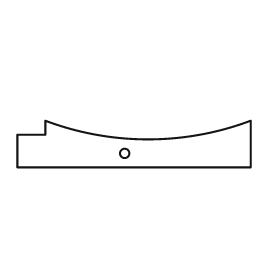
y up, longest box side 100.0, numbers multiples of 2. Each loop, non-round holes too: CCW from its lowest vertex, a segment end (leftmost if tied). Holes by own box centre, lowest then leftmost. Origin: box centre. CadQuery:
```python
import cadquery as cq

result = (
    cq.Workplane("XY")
    .moveTo(-50.0, -10.0)
    .lineTo(50.0, -10.0)
    .lineTo(50.0, 10.0)
    .threePointArc((6.0, 2.0), (-38.0, 10.0))
    .lineTo(-38.0, 4.0)
    .lineTo(-50.0, 4.0)
    .close()
    .moveTo(-4.0, -4.0)
    .circle(2.0)
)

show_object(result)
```